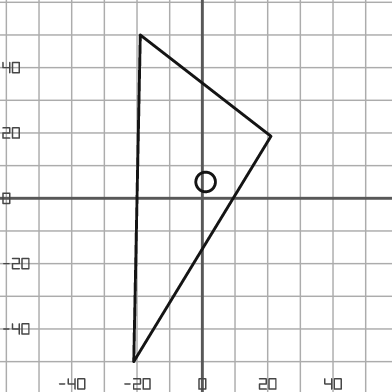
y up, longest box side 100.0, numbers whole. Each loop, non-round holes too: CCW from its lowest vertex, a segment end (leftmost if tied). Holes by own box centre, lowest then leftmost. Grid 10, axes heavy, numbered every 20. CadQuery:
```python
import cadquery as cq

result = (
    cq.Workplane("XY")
    .moveTo(-21.0, -50.0)
    .lineTo(21.0, 19.0)
    .lineTo(-19.0, 50.0)
    .close()
    .moveTo(1.0, 5.0)
    .circle(3.0)
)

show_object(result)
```